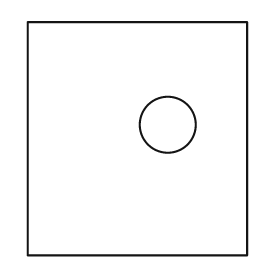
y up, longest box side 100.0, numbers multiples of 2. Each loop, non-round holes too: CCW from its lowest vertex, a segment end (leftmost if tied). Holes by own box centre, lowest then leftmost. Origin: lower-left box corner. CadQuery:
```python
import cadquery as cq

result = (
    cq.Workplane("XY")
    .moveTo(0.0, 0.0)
    .lineTo(94.0, 0.0)
    .lineTo(94.0, 100.0)
    .lineTo(0.0, 100.0)
    .close()
    .moveTo(60.0, 56.0)
    .circle(12.0)
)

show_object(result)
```